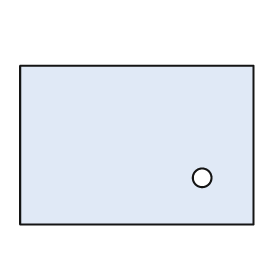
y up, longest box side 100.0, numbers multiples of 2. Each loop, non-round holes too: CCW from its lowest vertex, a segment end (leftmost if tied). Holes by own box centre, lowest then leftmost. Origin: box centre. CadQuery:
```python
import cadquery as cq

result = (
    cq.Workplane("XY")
    .moveTo(-50.0, -34.0)
    .lineTo(50.0, -34.0)
    .lineTo(50.0, 34.0)
    .lineTo(-50.0, 34.0)
    .close()
    .moveTo(28.0, -14.0)
    .circle(4.0)
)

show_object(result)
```